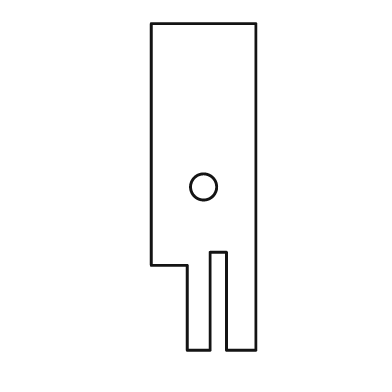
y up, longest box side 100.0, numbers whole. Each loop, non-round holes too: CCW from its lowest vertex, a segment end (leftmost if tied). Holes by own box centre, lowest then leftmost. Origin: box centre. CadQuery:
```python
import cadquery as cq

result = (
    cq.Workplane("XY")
    .moveTo(-5.0, -50.0)
    .lineTo(2.0, -50.0)
    .lineTo(2.0, -20.0)
    .lineTo(7.0, -20.0)
    .lineTo(7.0, -50.0)
    .lineTo(16.0, -50.0)
    .lineTo(16.0, 50.0)
    .lineTo(-16.0, 50.0)
    .lineTo(-16.0, -24.0)
    .lineTo(-5.0, -24.0)
    .close()
    .moveTo(0.0, 0.0)
    .circle(4.0)
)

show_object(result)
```